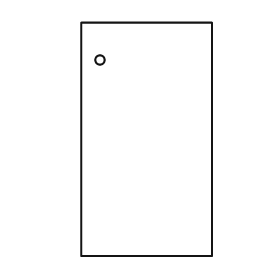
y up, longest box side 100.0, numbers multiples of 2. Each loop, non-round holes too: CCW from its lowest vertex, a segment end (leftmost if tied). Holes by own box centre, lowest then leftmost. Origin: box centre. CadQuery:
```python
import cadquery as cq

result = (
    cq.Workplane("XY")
    .moveTo(-28.0, -50.0)
    .lineTo(28.0, -50.0)
    .lineTo(28.0, 50.0)
    .lineTo(-28.0, 50.0)
    .close()
    .moveTo(-20.0, 34.0)
    .circle(2.0)
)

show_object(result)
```